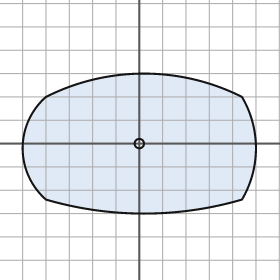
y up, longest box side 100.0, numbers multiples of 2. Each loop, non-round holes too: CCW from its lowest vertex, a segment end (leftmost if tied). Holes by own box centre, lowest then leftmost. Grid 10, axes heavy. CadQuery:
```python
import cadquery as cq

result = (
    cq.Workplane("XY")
    .moveTo(-40.0, -24.0)
    .threePointArc((2.0, -30.0), (44.0, -24.0))
    .threePointArc((50.0, -2.0), (44.0, 20.0))
    .threePointArc((2.0, 30.0), (-40.0, 20.0))
    .threePointArc((-50.0, -2.0), (-40.0, -24.0))
    .close()
    .moveTo(0.0, 0.0)
    .circle(2.0)
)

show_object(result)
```